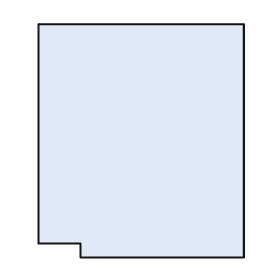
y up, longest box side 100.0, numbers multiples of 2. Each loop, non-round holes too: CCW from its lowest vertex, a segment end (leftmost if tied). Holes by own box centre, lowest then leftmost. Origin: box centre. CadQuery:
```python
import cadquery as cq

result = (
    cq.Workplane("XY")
    .moveTo(-26.0, -50.0)
    .lineTo(44.0, -50.0)
    .lineTo(44.0, 50.0)
    .lineTo(-44.0, 50.0)
    .lineTo(-44.0, -44.0)
    .lineTo(-26.0, -44.0)
    .close()
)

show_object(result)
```